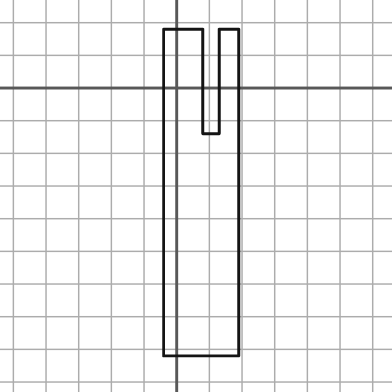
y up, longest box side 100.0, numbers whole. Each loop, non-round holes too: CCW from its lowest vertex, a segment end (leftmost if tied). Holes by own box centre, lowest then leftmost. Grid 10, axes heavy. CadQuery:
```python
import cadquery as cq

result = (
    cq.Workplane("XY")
    .moveTo(-4.0, -82.0)
    .lineTo(19.0, -82.0)
    .lineTo(19.0, 18.0)
    .lineTo(13.0, 18.0)
    .lineTo(13.0, -14.0)
    .lineTo(8.0, -14.0)
    .lineTo(8.0, 18.0)
    .lineTo(-4.0, 18.0)
    .close()
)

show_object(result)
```